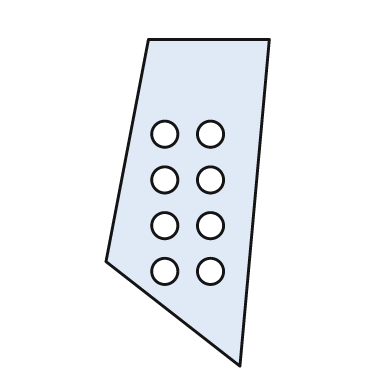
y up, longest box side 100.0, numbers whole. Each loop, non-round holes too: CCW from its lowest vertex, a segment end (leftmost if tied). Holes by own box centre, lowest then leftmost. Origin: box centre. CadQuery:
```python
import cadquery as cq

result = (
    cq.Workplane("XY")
    .moveTo(16.0, -50.0)
    .lineTo(25.0, 50.0)
    .lineTo(-12.0, 50.0)
    .lineTo(-25.0, -18.0)
    .close()
    .moveTo(-7.0, -21.0)
    .circle(4.0)
    .moveTo(7.0, -21.0)
    .circle(4.0)
    .moveTo(-7.0, -7.0)
    .circle(4.0)
    .moveTo(7.0, -7.0)
    .circle(4.0)
    .moveTo(-7.0, 7.0)
    .circle(4.0)
    .moveTo(7.0, 7.0)
    .circle(4.0)
    .moveTo(-7.0, 21.0)
    .circle(4.0)
    .moveTo(7.0, 21.0)
    .circle(4.0)
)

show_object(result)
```